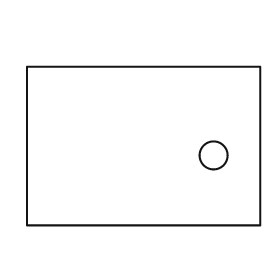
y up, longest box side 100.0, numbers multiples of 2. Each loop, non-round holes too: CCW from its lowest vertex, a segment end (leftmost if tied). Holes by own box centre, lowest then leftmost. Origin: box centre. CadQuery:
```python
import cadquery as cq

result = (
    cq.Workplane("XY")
    .moveTo(-50.0, -34.0)
    .lineTo(50.0, -34.0)
    .lineTo(50.0, 34.0)
    .lineTo(-50.0, 34.0)
    .close()
    .moveTo(30.0, -4.0)
    .circle(6.0)
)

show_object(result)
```